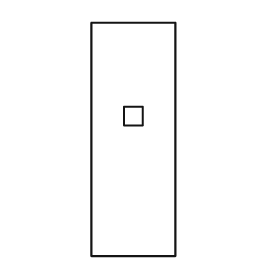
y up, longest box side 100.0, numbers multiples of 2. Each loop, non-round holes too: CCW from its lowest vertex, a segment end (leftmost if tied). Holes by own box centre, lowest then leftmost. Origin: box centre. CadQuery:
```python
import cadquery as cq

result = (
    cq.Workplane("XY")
    .moveTo(-18.0, -50.0)
    .lineTo(18.0, -50.0)
    .lineTo(18.0, 50.0)
    .lineTo(-18.0, 50.0)
    .close()
    .moveTo(-4.0, 6.0)
    .lineTo(4.0, 6.0)
    .lineTo(4.0, 14.0)
    .lineTo(-4.0, 14.0)
    .close()
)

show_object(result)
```